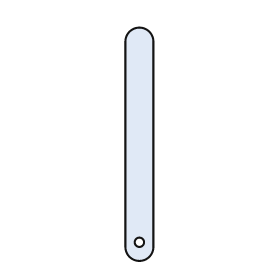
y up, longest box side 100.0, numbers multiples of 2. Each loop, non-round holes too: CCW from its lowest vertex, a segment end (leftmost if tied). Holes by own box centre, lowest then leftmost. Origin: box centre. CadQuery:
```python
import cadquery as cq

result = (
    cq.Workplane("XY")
    .moveTo(-6.0, -44.0)
    .threePointArc((0.0, -50.0), (6.0, -44.0))
    .lineTo(6.0, 44.0)
    .threePointArc((0.0, 50.0), (-6.0, 44.0))
    .close()
    .moveTo(0.0, -42.0)
    .circle(2.0)
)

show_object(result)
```